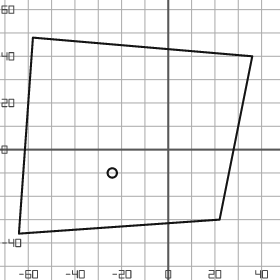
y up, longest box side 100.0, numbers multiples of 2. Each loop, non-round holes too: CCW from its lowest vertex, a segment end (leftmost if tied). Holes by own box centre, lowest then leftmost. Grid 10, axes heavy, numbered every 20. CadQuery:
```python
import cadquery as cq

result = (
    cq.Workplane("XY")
    .moveTo(-64.0, -36.0)
    .lineTo(22.0, -30.0)
    .lineTo(36.0, 40.0)
    .lineTo(-58.0, 48.0)
    .close()
    .moveTo(-24.0, -10.0)
    .circle(2.0)
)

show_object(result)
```